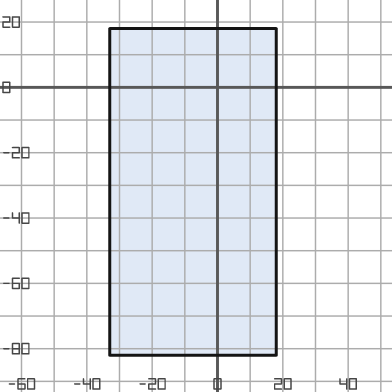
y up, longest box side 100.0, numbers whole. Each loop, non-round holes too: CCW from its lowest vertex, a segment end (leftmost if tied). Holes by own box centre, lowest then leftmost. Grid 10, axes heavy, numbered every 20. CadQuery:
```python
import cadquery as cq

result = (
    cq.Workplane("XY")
    .moveTo(-33.0, -82.0)
    .lineTo(18.0, -82.0)
    .lineTo(18.0, 18.0)
    .lineTo(-33.0, 18.0)
    .close()
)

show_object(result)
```